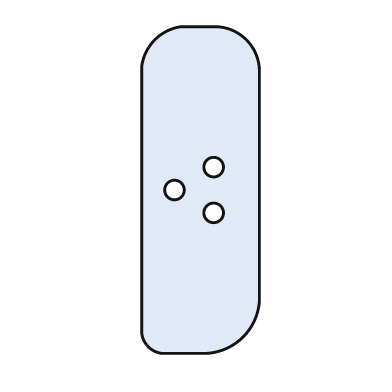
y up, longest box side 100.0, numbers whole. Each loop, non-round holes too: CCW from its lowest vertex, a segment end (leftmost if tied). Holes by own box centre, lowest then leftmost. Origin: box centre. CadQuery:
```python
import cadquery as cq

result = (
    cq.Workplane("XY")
    .moveTo(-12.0, -50.0)
    .lineTo(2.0, -50.0)
    .threePointArc((13.0, -45.0), (18.0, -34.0))
    .lineTo(18.0, 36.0)
    .threePointArc((14.0, 46.0), (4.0, 50.0))
    .lineTo(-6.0, 50.0)
    .threePointArc((-14.0, 46.0), (-18.0, 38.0))
    .lineTo(-18.0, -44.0)
    .threePointArc((-16.0, -48.0), (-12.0, -50.0))
    .close()
    .moveTo(4.0, -7.0)
    .circle(3.0)
    .moveTo(-8.0, 0.0)
    .circle(3.0)
    .moveTo(4.0, 7.0)
    .circle(3.0)
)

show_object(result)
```